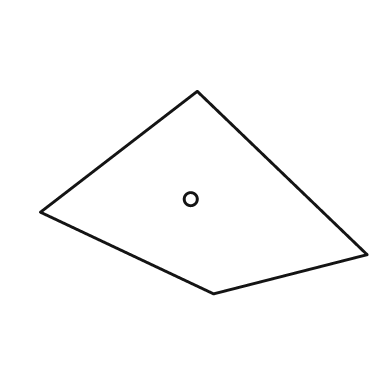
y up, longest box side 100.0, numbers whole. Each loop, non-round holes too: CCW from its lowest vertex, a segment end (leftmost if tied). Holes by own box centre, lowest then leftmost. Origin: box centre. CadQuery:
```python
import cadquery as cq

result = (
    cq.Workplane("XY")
    .moveTo(3.0, -31.0)
    .lineTo(50.0, -19.0)
    .lineTo(-2.0, 31.0)
    .lineTo(-50.0, -6.0)
    .close()
    .moveTo(-4.0, -2.0)
    .circle(2.0)
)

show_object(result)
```